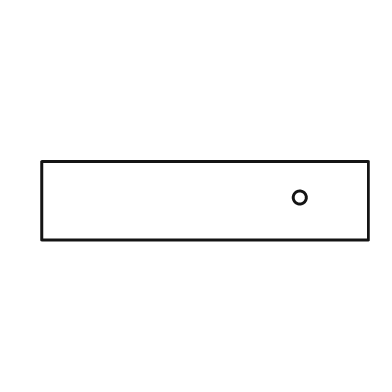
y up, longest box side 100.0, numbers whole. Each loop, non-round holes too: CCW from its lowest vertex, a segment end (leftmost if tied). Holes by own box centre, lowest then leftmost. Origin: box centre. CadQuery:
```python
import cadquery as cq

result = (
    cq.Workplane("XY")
    .moveTo(-50.0, -12.0)
    .lineTo(50.0, -12.0)
    .lineTo(50.0, 12.0)
    .lineTo(-50.0, 12.0)
    .close()
    .moveTo(29.0, 1.0)
    .circle(2.0)
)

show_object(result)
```